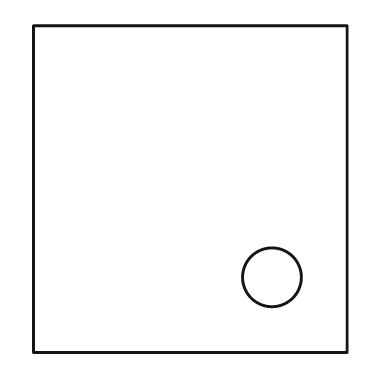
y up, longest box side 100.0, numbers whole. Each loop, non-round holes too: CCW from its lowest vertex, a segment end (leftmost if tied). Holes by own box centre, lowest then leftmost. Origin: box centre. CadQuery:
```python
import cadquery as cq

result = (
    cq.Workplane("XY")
    .moveTo(-48.0, -50.0)
    .lineTo(48.0, -50.0)
    .lineTo(48.0, 50.0)
    .lineTo(-48.0, 50.0)
    .close()
    .moveTo(25.0, -27.0)
    .circle(9.0)
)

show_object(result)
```